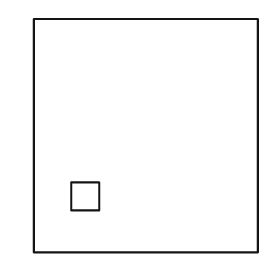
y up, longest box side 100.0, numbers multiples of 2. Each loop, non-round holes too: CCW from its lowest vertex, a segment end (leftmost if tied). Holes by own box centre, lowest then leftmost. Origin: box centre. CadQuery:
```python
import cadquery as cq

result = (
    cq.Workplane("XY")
    .moveTo(-48.0, -50.0)
    .lineTo(48.0, -50.0)
    .lineTo(48.0, 50.0)
    .lineTo(-48.0, 50.0)
    .close()
    .moveTo(-32.0, -32.0)
    .lineTo(-20.0, -32.0)
    .lineTo(-20.0, -20.0)
    .lineTo(-32.0, -20.0)
    .close()
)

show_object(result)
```